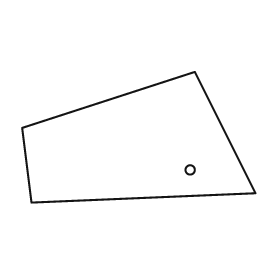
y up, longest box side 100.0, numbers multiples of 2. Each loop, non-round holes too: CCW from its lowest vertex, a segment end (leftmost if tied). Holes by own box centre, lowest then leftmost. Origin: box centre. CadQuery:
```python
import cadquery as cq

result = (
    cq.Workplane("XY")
    .moveTo(-46.0, -28.0)
    .lineTo(50.0, -24.0)
    .lineTo(24.0, 28.0)
    .lineTo(-50.0, 4.0)
    .close()
    .moveTo(22.0, -14.0)
    .circle(2.0)
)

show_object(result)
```